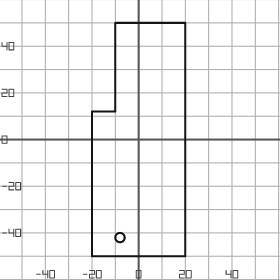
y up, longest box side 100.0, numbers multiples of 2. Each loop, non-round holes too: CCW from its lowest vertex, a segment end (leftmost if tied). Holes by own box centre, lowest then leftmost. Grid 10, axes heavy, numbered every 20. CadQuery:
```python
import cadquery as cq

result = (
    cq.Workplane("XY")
    .moveTo(-20.0, -50.0)
    .lineTo(20.0, -50.0)
    .lineTo(20.0, 50.0)
    .lineTo(-10.0, 50.0)
    .lineTo(-10.0, 12.0)
    .lineTo(-20.0, 12.0)
    .close()
    .moveTo(-8.0, -42.0)
    .circle(2.0)
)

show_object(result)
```